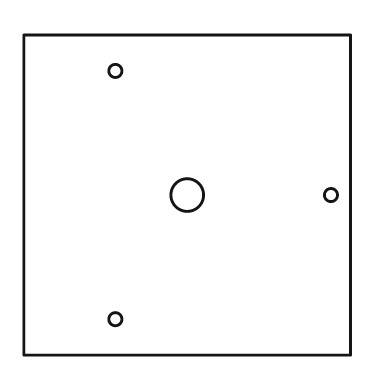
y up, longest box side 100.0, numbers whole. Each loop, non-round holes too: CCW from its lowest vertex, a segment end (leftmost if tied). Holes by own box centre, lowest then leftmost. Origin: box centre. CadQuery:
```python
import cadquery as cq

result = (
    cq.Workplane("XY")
    .moveTo(-50.0, -49.0)
    .lineTo(50.0, -49.0)
    .lineTo(50.0, 49.0)
    .lineTo(-50.0, 49.0)
    .close()
    .moveTo(-22.0, -38.0)
    .circle(2.0)
    .moveTo(0.0, 0.0)
    .circle(5.0)
    .moveTo(44.0, 0.0)
    .circle(2.0)
    .moveTo(-22.0, 38.0)
    .circle(2.0)
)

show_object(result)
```